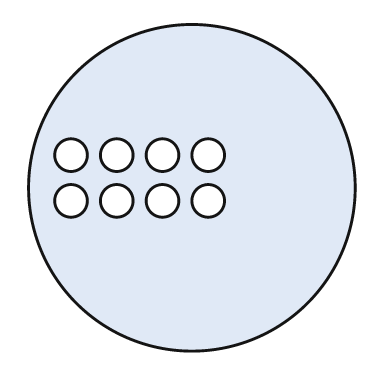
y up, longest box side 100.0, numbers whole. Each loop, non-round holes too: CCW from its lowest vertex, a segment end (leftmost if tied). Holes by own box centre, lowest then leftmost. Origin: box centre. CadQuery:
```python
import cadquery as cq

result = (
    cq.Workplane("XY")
    .moveTo(0.0, 0.0)
    .circle(50.0)
    .moveTo(-37.0, -4.0)
    .circle(5.0)
    .moveTo(-23.0, -4.0)
    .circle(5.0)
    .moveTo(-9.0, -4.0)
    .circle(5.0)
    .moveTo(5.0, -4.0)
    .circle(5.0)
    .moveTo(-37.0, 10.0)
    .circle(5.0)
    .moveTo(-23.0, 10.0)
    .circle(5.0)
    .moveTo(-9.0, 10.0)
    .circle(5.0)
    .moveTo(5.0, 10.0)
    .circle(5.0)
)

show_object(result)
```